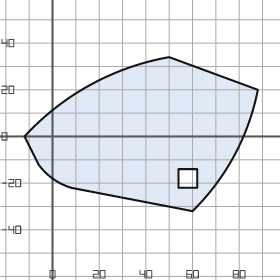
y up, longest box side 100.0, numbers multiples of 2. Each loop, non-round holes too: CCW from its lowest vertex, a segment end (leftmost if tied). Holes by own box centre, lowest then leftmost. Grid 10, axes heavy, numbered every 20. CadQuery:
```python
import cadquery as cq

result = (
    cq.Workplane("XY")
    .moveTo(60.0, -32.0)
    .threePointArc((78.0, -8.0), (88.0, 20.0))
    .lineTo(50.0, 34.0)
    .threePointArc((16.0, 22.0), (-12.0, 0.0))
    .lineTo(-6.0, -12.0)
    .threePointArc((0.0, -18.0), (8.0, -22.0))
    .close()
    .moveTo(54.0, -22.0)
    .lineTo(62.0, -22.0)
    .lineTo(62.0, -14.0)
    .lineTo(54.0, -14.0)
    .close()
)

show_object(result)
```